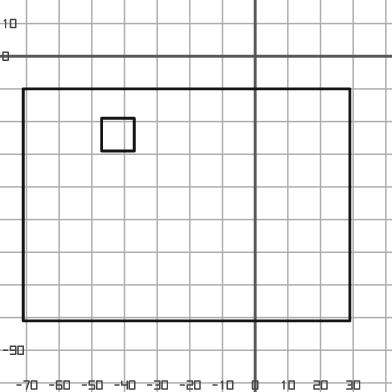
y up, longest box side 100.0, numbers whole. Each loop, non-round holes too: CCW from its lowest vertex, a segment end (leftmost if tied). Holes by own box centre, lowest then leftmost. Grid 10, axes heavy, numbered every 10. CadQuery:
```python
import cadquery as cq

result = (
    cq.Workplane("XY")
    .moveTo(-71.0, -81.0)
    .lineTo(29.0, -81.0)
    .lineTo(29.0, -10.0)
    .lineTo(-71.0, -10.0)
    .close()
    .moveTo(-47.0, -29.0)
    .lineTo(-37.0, -29.0)
    .lineTo(-37.0, -19.0)
    .lineTo(-47.0, -19.0)
    .close()
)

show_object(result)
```